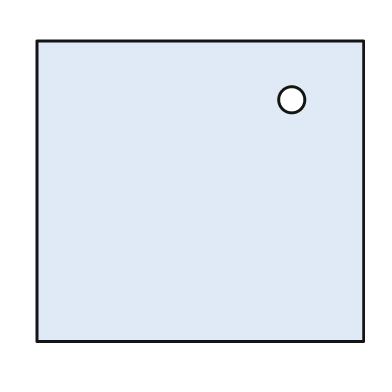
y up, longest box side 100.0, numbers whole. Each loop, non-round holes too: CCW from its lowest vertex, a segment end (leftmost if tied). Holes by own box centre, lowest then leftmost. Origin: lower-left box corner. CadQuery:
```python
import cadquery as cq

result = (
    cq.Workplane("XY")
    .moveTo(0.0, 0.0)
    .lineTo(100.0, 0.0)
    .lineTo(100.0, 92.0)
    .lineTo(0.0, 92.0)
    .close()
    .moveTo(78.0, 74.0)
    .circle(4.0)
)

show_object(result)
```